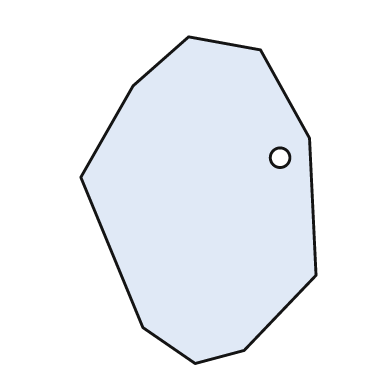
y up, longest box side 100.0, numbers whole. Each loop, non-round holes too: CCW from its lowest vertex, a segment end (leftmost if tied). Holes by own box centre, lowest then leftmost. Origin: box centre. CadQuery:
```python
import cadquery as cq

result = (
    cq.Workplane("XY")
    .moveTo(-1.0, -50.0)
    .lineTo(14.0, -46.0)
    .lineTo(36.0, -23.0)
    .lineTo(34.0, 19.0)
    .lineTo(19.0, 46.0)
    .lineTo(-3.0, 50.0)
    .lineTo(-20.0, 35.0)
    .lineTo(-36.0, 7.0)
    .lineTo(-17.0, -39.0)
    .close()
    .moveTo(25.0, 13.0)
    .circle(3.0)
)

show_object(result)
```